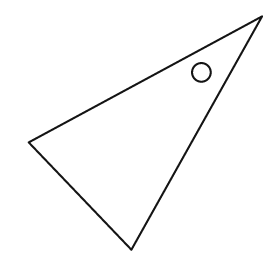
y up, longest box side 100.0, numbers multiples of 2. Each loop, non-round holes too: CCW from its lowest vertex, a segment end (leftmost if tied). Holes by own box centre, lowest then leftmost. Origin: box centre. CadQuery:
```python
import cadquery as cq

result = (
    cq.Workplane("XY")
    .moveTo(-6.0, -50.0)
    .lineTo(50.0, 50.0)
    .lineTo(-50.0, -4.0)
    .close()
    .moveTo(24.0, 26.0)
    .circle(4.0)
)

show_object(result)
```